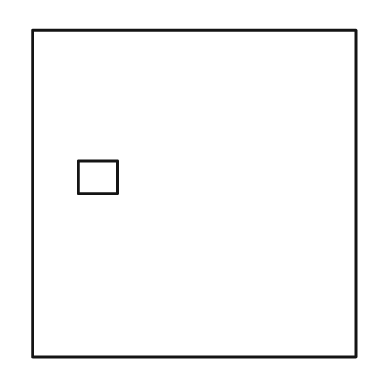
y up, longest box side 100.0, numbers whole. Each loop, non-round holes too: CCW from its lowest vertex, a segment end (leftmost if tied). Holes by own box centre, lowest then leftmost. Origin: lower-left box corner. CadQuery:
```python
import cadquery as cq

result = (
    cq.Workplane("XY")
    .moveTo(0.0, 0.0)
    .lineTo(99.0, 0.0)
    .lineTo(99.0, 100.0)
    .lineTo(0.0, 100.0)
    .close()
    .moveTo(14.0, 50.0)
    .lineTo(26.0, 50.0)
    .lineTo(26.0, 60.0)
    .lineTo(14.0, 60.0)
    .close()
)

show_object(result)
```